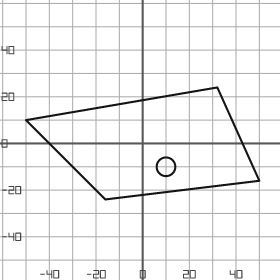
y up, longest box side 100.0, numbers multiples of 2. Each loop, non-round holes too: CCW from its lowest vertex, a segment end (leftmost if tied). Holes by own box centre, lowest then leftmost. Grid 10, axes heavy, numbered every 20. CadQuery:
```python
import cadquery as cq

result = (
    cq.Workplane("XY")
    .moveTo(-16.0, -24.0)
    .lineTo(50.0, -16.0)
    .lineTo(32.0, 24.0)
    .lineTo(-50.0, 10.0)
    .close()
    .moveTo(10.0, -10.0)
    .circle(4.0)
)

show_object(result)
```